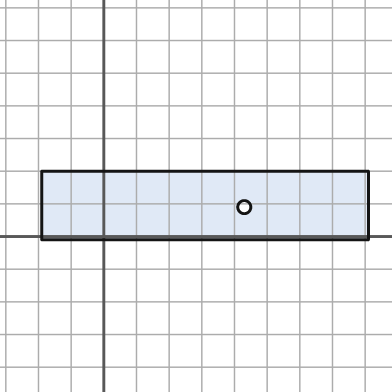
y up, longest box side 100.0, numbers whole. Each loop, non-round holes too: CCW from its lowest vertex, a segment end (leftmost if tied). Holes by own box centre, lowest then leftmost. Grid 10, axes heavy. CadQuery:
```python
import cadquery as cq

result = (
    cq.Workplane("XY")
    .moveTo(-19.0, -1.0)
    .lineTo(81.0, -1.0)
    .lineTo(81.0, 20.0)
    .lineTo(-19.0, 20.0)
    .close()
    .moveTo(43.0, 9.0)
    .circle(2.0)
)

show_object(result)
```